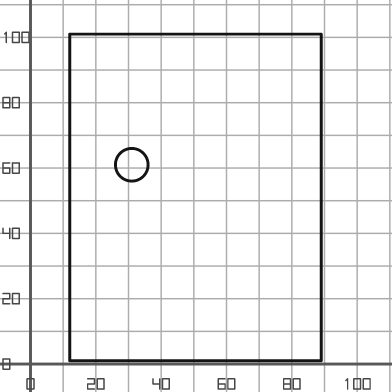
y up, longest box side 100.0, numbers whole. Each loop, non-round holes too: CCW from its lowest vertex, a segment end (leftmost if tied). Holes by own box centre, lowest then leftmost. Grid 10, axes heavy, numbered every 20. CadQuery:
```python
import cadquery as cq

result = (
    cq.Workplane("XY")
    .moveTo(12.0, 1.0)
    .lineTo(89.0, 1.0)
    .lineTo(89.0, 101.0)
    .lineTo(12.0, 101.0)
    .close()
    .moveTo(31.0, 61.0)
    .circle(5.0)
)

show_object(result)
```